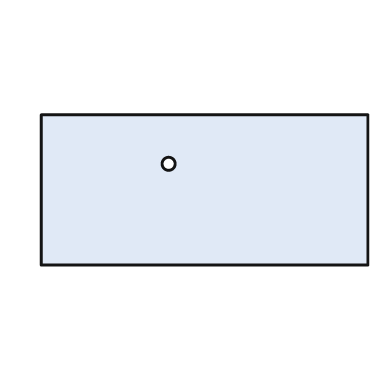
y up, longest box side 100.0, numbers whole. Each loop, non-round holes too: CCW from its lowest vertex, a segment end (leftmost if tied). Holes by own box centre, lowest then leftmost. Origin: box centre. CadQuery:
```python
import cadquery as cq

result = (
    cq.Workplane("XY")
    .moveTo(-50.0, -23.0)
    .lineTo(50.0, -23.0)
    .lineTo(50.0, 23.0)
    .lineTo(-50.0, 23.0)
    .close()
    .moveTo(-11.0, 8.0)
    .circle(2.0)
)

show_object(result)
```